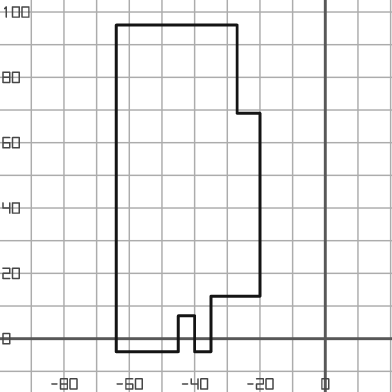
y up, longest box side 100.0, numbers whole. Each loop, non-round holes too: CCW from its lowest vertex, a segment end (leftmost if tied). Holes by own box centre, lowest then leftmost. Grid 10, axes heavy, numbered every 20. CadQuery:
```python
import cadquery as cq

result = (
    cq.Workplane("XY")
    .moveTo(-64.0, -4.0)
    .lineTo(-45.0, -4.0)
    .lineTo(-45.0, 7.0)
    .lineTo(-40.0, 7.0)
    .lineTo(-40.0, -4.0)
    .lineTo(-35.0, -4.0)
    .lineTo(-35.0, 13.0)
    .lineTo(-20.0, 13.0)
    .lineTo(-20.0, 69.0)
    .lineTo(-27.0, 69.0)
    .lineTo(-27.0, 96.0)
    .lineTo(-64.0, 96.0)
    .close()
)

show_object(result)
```